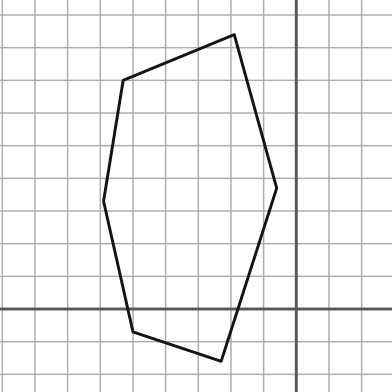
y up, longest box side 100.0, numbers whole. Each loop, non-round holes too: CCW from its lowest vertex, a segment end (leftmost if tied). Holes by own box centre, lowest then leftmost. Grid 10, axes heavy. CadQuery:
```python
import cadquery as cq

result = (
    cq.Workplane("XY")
    .moveTo(-23.0, -16.0)
    .lineTo(-6.0, 37.0)
    .lineTo(-19.0, 84.0)
    .lineTo(-53.0, 70.0)
    .lineTo(-59.0, 33.0)
    .lineTo(-50.0, -7.0)
    .close()
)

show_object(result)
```